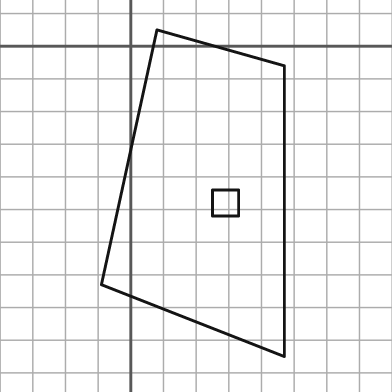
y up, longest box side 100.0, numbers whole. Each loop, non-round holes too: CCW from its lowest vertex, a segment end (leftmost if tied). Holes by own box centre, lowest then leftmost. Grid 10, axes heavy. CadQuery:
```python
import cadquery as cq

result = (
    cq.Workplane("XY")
    .moveTo(47.0, -95.0)
    .lineTo(47.0, -6.0)
    .lineTo(8.0, 5.0)
    .lineTo(-9.0, -73.0)
    .close()
    .moveTo(25.0, -52.0)
    .lineTo(33.0, -52.0)
    .lineTo(33.0, -44.0)
    .lineTo(25.0, -44.0)
    .close()
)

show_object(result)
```